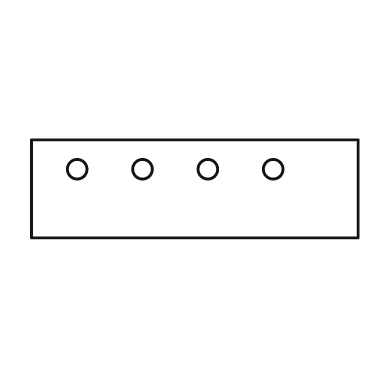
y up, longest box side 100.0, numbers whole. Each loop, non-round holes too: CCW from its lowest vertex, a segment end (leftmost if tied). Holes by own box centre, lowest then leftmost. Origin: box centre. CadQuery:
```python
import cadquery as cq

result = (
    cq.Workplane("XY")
    .moveTo(-50.0, -15.0)
    .lineTo(50.0, -15.0)
    .lineTo(50.0, 15.0)
    .lineTo(-50.0, 15.0)
    .close()
    .moveTo(-36.0, 6.0)
    .circle(3.0)
    .moveTo(-16.0, 6.0)
    .circle(3.0)
    .moveTo(4.0, 6.0)
    .circle(3.0)
    .moveTo(24.0, 6.0)
    .circle(3.0)
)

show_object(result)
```